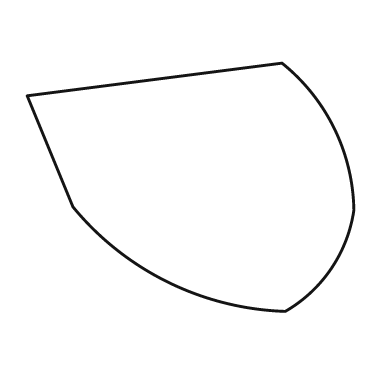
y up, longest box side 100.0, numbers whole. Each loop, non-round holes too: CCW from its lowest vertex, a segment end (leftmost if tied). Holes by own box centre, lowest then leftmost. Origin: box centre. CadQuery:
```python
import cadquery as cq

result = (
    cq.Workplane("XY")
    .moveTo(29.0, -38.0)
    .threePointArc((43.0, -25.0), (50.0, -7.0))
    .threePointArc((44.0, 18.0), (28.0, 38.0))
    .lineTo(-50.0, 28.0)
    .lineTo(-36.0, -6.0)
    .threePointArc((-7.0, -29.0), (29.0, -38.0))
    .close()
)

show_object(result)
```